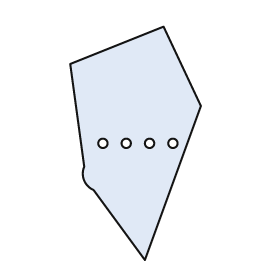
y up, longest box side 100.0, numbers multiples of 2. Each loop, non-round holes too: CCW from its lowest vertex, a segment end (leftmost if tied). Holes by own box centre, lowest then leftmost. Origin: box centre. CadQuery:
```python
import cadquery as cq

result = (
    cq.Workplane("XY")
    .moveTo(4.0, -50.0)
    .lineTo(28.0, 16.0)
    .lineTo(12.0, 50.0)
    .lineTo(-28.0, 34.0)
    .lineTo(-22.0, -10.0)
    .threePointArc((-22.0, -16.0), (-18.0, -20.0))
    .close()
    .moveTo(-14.0, 0.0)
    .circle(2.0)
    .moveTo(-4.0, 0.0)
    .circle(2.0)
    .moveTo(6.0, 0.0)
    .circle(2.0)
    .moveTo(16.0, 0.0)
    .circle(2.0)
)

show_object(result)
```